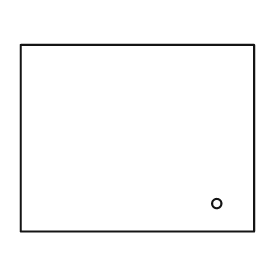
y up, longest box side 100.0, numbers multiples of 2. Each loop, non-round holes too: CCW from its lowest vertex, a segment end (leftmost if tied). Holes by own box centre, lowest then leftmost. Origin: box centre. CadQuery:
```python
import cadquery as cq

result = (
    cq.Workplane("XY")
    .moveTo(-50.0, -40.0)
    .lineTo(50.0, -40.0)
    .lineTo(50.0, 40.0)
    .lineTo(-50.0, 40.0)
    .close()
    .moveTo(34.0, -28.0)
    .circle(2.0)
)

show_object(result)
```